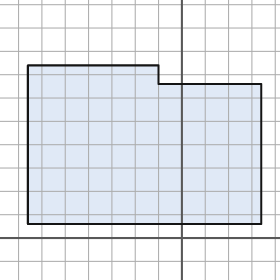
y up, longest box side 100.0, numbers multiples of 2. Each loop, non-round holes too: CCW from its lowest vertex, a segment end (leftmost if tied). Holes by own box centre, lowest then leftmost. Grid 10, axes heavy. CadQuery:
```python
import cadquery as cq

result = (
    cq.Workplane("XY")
    .moveTo(-66.0, 6.0)
    .lineTo(34.0, 6.0)
    .lineTo(34.0, 66.0)
    .lineTo(-10.0, 66.0)
    .lineTo(-10.0, 74.0)
    .lineTo(-66.0, 74.0)
    .close()
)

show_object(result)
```